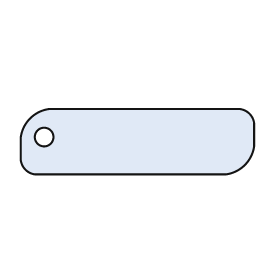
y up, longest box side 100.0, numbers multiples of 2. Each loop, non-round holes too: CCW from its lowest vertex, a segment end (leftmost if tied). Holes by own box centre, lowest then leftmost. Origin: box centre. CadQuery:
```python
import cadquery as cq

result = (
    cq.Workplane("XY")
    .moveTo(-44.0, -14.0)
    .lineTo(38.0, -14.0)
    .threePointArc((46.0, -10.0), (50.0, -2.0))
    .lineTo(50.0, 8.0)
    .threePointArc((48.0, 12.0), (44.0, 14.0))
    .lineTo(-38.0, 14.0)
    .threePointArc((-46.0, 10.0), (-50.0, 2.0))
    .lineTo(-50.0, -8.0)
    .threePointArc((-48.0, -12.0), (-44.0, -14.0))
    .close()
    .moveTo(-40.0, 2.0)
    .circle(4.0)
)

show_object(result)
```